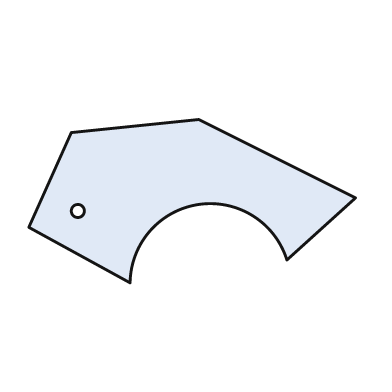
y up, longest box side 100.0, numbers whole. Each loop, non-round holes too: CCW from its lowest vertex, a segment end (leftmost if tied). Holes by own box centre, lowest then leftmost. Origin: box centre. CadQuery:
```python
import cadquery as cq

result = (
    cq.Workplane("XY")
    .moveTo(-19.0, -25.0)
    .threePointArc((2.0, -1.0), (29.0, -18.0))
    .lineTo(50.0, 1.0)
    .lineTo(2.0, 25.0)
    .lineTo(-37.0, 21.0)
    .lineTo(-50.0, -8.0)
    .close()
    .moveTo(-35.0, -3.0)
    .circle(2.0)
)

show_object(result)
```